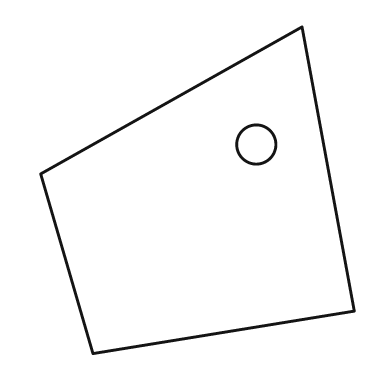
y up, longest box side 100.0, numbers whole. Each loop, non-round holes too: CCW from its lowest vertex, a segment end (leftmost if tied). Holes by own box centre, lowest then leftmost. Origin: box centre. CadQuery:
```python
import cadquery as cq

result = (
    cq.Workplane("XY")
    .moveTo(-32.0, -50.0)
    .lineTo(48.0, -37.0)
    .lineTo(32.0, 50.0)
    .lineTo(-48.0, 5.0)
    .close()
    .moveTo(18.0, 14.0)
    .circle(6.0)
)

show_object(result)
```